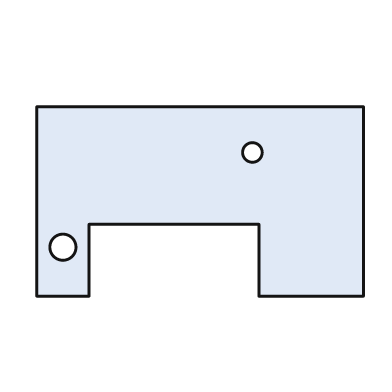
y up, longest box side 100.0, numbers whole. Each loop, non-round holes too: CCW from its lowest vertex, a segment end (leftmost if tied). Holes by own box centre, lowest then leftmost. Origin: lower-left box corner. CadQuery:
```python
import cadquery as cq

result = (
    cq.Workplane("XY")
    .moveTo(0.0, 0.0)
    .lineTo(16.0, 0.0)
    .lineTo(16.0, 22.0)
    .lineTo(68.0, 22.0)
    .lineTo(68.0, 0.0)
    .lineTo(100.0, 0.0)
    .lineTo(100.0, 58.0)
    .lineTo(0.0, 58.0)
    .close()
    .moveTo(8.0, 15.0)
    .circle(4.0)
    .moveTo(66.0, 44.0)
    .circle(3.0)
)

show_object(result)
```